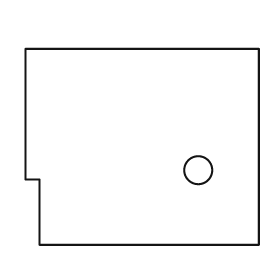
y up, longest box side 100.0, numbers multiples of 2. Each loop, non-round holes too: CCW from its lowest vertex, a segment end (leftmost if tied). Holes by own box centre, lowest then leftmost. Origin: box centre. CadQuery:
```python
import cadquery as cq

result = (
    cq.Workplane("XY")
    .moveTo(-44.0, -42.0)
    .lineTo(50.0, -42.0)
    .lineTo(50.0, 42.0)
    .lineTo(-50.0, 42.0)
    .lineTo(-50.0, -14.0)
    .lineTo(-44.0, -14.0)
    .close()
    .moveTo(24.0, -10.0)
    .circle(6.0)
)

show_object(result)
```